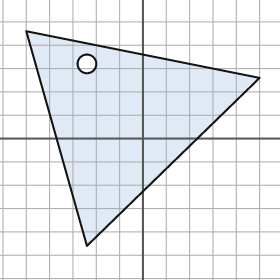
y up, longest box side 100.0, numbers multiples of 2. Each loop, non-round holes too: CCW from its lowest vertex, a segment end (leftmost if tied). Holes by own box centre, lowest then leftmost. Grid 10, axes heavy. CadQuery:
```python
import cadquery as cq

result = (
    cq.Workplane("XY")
    .moveTo(-24.0, -46.0)
    .lineTo(50.0, 26.0)
    .lineTo(-50.0, 46.0)
    .close()
    .moveTo(-24.0, 32.0)
    .circle(4.0)
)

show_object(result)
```